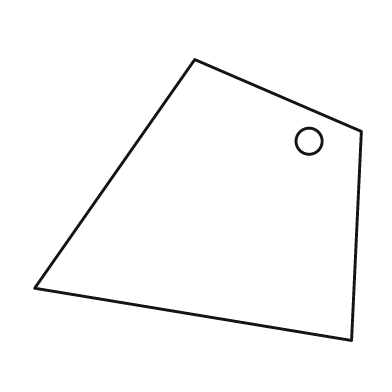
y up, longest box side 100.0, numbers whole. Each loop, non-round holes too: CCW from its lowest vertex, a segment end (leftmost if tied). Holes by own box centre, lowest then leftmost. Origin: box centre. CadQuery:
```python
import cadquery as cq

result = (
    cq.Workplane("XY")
    .moveTo(47.0, -43.0)
    .lineTo(50.0, 21.0)
    .lineTo(-1.0, 43.0)
    .lineTo(-50.0, -27.0)
    .close()
    .moveTo(34.0, 18.0)
    .circle(4.0)
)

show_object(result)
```